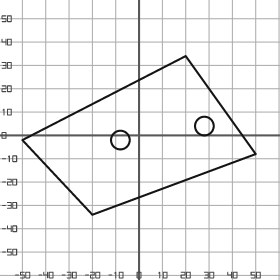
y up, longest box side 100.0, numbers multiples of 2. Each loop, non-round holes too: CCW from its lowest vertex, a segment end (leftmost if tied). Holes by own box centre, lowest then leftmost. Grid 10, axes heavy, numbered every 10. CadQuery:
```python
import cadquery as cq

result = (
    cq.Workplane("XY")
    .moveTo(-20.0, -34.0)
    .lineTo(50.0, -8.0)
    .lineTo(20.0, 34.0)
    .lineTo(-50.0, -2.0)
    .close()
    .moveTo(-8.0, -2.0)
    .circle(4.0)
    .moveTo(28.0, 4.0)
    .circle(4.0)
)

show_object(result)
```